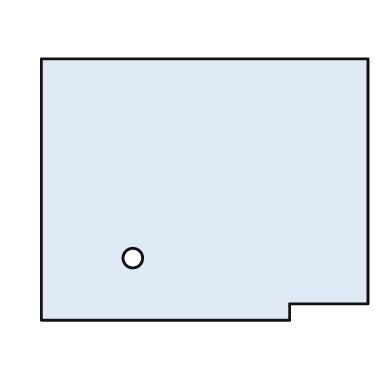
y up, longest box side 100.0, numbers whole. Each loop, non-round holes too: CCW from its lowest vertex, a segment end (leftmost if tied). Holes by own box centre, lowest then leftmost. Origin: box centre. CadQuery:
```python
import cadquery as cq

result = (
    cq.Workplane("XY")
    .moveTo(-50.0, -40.0)
    .lineTo(26.0, -40.0)
    .lineTo(26.0, -35.0)
    .lineTo(50.0, -35.0)
    .lineTo(50.0, 40.0)
    .lineTo(-50.0, 40.0)
    .close()
    .moveTo(-22.0, -21.0)
    .circle(3.0)
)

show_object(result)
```